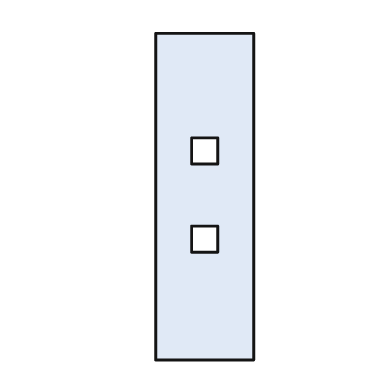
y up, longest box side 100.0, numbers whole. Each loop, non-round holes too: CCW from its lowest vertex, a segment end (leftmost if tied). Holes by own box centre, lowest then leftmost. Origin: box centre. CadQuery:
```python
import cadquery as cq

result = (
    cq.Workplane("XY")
    .moveTo(-15.0, -50.0)
    .lineTo(15.0, -50.0)
    .lineTo(15.0, 50.0)
    .lineTo(-15.0, 50.0)
    .close()
    .moveTo(-4.0, -17.0)
    .lineTo(4.0, -17.0)
    .lineTo(4.0, -9.0)
    .lineTo(-4.0, -9.0)
    .close()
    .moveTo(-4.0, 10.0)
    .lineTo(4.0, 10.0)
    .lineTo(4.0, 18.0)
    .lineTo(-4.0, 18.0)
    .close()
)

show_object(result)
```